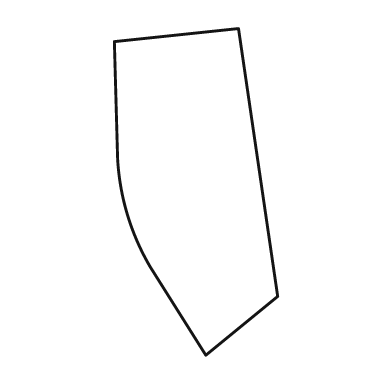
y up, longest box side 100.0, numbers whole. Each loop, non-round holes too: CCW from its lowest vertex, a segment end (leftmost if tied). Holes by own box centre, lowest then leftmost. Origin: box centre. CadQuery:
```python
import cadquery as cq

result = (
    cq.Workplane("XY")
    .moveTo(3.0, -50.0)
    .lineTo(25.0, -32.0)
    .lineTo(13.0, 50.0)
    .lineTo(-25.0, 46.0)
    .lineTo(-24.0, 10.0)
    .threePointArc((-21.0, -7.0), (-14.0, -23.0))
    .close()
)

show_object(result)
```